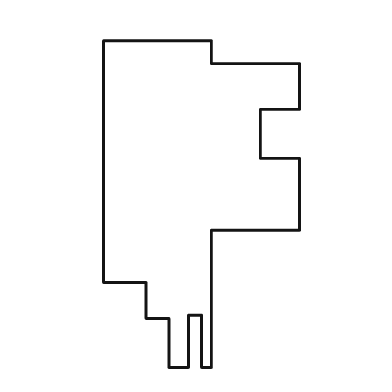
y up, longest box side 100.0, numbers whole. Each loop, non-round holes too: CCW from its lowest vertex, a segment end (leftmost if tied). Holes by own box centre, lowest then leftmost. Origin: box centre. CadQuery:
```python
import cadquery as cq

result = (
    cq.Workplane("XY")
    .moveTo(-10.0, -50.0)
    .lineTo(-4.0, -50.0)
    .lineTo(-4.0, -34.0)
    .lineTo(0.0, -34.0)
    .lineTo(0.0, -50.0)
    .lineTo(3.0, -50.0)
    .lineTo(3.0, -8.0)
    .lineTo(30.0, -8.0)
    .lineTo(30.0, 14.0)
    .lineTo(18.0, 14.0)
    .lineTo(18.0, 29.0)
    .lineTo(30.0, 29.0)
    .lineTo(30.0, 43.0)
    .lineTo(3.0, 43.0)
    .lineTo(3.0, 50.0)
    .lineTo(-30.0, 50.0)
    .lineTo(-30.0, -24.0)
    .lineTo(-17.0, -24.0)
    .lineTo(-17.0, -35.0)
    .lineTo(-10.0, -35.0)
    .close()
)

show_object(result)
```